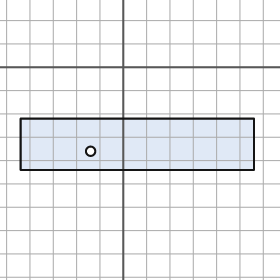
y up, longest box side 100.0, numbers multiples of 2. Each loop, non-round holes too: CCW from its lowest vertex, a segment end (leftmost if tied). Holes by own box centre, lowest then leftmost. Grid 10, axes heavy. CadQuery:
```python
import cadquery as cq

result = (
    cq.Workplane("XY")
    .moveTo(-44.0, -44.0)
    .lineTo(56.0, -44.0)
    .lineTo(56.0, -22.0)
    .lineTo(-44.0, -22.0)
    .close()
    .moveTo(-14.0, -36.0)
    .circle(2.0)
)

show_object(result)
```